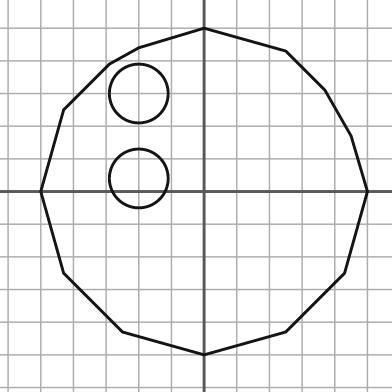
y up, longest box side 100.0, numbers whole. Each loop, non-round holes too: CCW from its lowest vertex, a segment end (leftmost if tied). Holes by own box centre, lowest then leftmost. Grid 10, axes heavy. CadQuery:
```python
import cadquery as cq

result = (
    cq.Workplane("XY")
    .moveTo(0.0, -50.0)
    .lineTo(25.0, -43.0)
    .lineTo(43.0, -25.0)
    .lineTo(50.0, 0.0)
    .lineTo(45.0, 17.0)
    .lineTo(37.0, 31.0)
    .lineTo(25.0, 43.0)
    .lineTo(0.0, 50.0)
    .lineTo(-20.0, 44.0)
    .lineTo(-29.0, 39.0)
    .lineTo(-43.0, 25.0)
    .lineTo(-50.0, 0.0)
    .lineTo(-43.0, -25.0)
    .lineTo(-25.0, -43.0)
    .close()
    .moveTo(-20.0, 4.0)
    .circle(9.0)
    .moveTo(-20.0, 30.0)
    .circle(9.0)
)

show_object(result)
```